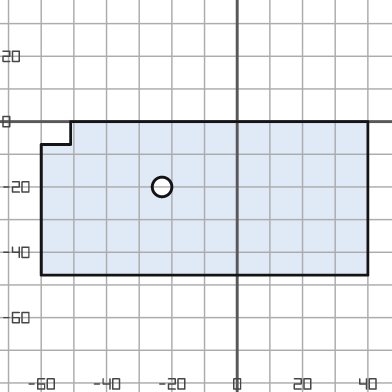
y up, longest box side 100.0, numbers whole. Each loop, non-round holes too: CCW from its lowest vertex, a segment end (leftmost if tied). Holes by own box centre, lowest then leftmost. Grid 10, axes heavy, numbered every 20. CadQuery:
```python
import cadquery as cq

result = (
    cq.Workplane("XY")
    .moveTo(-60.0, -47.0)
    .lineTo(40.0, -47.0)
    .lineTo(40.0, 0.0)
    .lineTo(-51.0, 0.0)
    .lineTo(-51.0, -7.0)
    .lineTo(-60.0, -7.0)
    .close()
    .moveTo(-23.0, -20.0)
    .circle(3.0)
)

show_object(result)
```